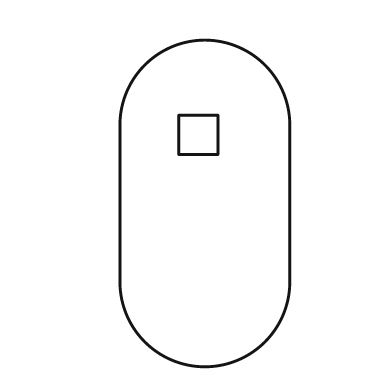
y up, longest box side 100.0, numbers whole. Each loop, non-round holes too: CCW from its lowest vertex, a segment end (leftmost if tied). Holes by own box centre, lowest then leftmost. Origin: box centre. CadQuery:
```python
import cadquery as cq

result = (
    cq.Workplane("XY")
    .moveTo(-26.0, -24.0)
    .threePointArc((0.0, -50.0), (26.0, -24.0))
    .lineTo(26.0, 24.0)
    .threePointArc((0.0, 50.0), (-26.0, 24.0))
    .close()
    .moveTo(-8.0, 15.0)
    .lineTo(4.0, 15.0)
    .lineTo(4.0, 27.0)
    .lineTo(-8.0, 27.0)
    .close()
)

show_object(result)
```